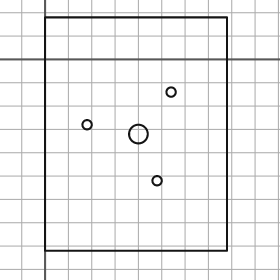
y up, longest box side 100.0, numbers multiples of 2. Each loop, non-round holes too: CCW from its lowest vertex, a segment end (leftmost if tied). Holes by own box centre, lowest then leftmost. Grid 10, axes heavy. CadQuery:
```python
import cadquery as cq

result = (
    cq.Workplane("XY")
    .moveTo(0.0, -82.0)
    .lineTo(78.0, -82.0)
    .lineTo(78.0, 18.0)
    .lineTo(0.0, 18.0)
    .close()
    .moveTo(48.0, -52.0)
    .circle(2.0)
    .moveTo(40.0, -32.0)
    .circle(4.0)
    .moveTo(18.0, -28.0)
    .circle(2.0)
    .moveTo(54.0, -14.0)
    .circle(2.0)
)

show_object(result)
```